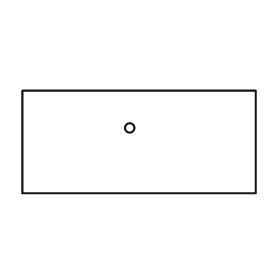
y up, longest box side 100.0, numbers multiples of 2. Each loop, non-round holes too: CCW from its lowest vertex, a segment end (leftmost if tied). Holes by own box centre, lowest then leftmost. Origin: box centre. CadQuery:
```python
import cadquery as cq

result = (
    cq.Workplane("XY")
    .moveTo(-50.0, -22.0)
    .lineTo(50.0, -22.0)
    .lineTo(50.0, 22.0)
    .lineTo(-50.0, 22.0)
    .close()
    .moveTo(-4.0, 6.0)
    .circle(2.0)
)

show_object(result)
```